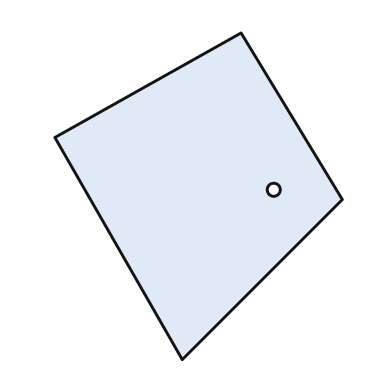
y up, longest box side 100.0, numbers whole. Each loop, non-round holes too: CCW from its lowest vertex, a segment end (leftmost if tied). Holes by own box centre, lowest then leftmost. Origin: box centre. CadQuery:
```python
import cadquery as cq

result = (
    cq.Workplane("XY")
    .moveTo(-5.0, -50.0)
    .lineTo(44.0, -1.0)
    .lineTo(13.0, 50.0)
    .lineTo(-44.0, 18.0)
    .close()
    .moveTo(23.0, 2.0)
    .circle(2.0)
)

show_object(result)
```